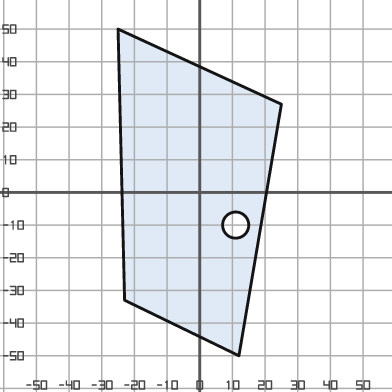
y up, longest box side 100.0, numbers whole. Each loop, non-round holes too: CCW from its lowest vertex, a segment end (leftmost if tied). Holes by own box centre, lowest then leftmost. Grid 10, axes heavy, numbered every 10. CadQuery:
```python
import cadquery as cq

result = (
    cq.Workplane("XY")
    .moveTo(12.0, -50.0)
    .lineTo(25.0, 27.0)
    .lineTo(-25.0, 50.0)
    .lineTo(-23.0, -33.0)
    .close()
    .moveTo(11.0, -10.0)
    .circle(4.0)
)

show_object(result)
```